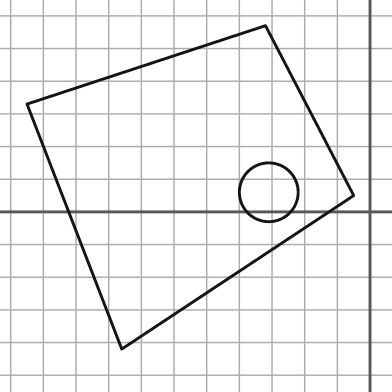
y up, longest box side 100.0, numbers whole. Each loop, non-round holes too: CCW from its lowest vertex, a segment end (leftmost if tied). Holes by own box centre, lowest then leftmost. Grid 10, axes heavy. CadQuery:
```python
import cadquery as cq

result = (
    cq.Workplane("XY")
    .moveTo(-76.0, -42.0)
    .lineTo(-5.0, 5.0)
    .lineTo(-32.0, 57.0)
    .lineTo(-105.0, 33.0)
    .close()
    .moveTo(-31.0, 6.0)
    .circle(9.0)
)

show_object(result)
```